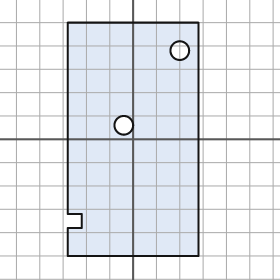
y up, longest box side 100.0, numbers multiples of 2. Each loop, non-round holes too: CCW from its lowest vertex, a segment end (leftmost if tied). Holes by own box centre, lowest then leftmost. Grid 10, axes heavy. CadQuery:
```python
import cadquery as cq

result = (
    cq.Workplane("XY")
    .moveTo(-28.0, -50.0)
    .lineTo(28.0, -50.0)
    .lineTo(28.0, 50.0)
    .lineTo(-28.0, 50.0)
    .lineTo(-28.0, -32.0)
    .lineTo(-22.0, -32.0)
    .lineTo(-22.0, -38.0)
    .lineTo(-28.0, -38.0)
    .close()
    .moveTo(-4.0, 6.0)
    .circle(4.0)
    .moveTo(20.0, 38.0)
    .circle(4.0)
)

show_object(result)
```